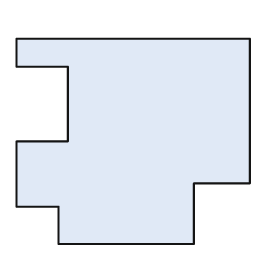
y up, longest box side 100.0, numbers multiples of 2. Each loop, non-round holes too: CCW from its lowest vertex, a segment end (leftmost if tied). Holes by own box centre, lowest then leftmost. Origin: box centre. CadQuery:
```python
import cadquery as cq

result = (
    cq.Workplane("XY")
    .moveTo(-32.0, -44.0)
    .lineTo(26.0, -44.0)
    .lineTo(26.0, -18.0)
    .lineTo(50.0, -18.0)
    .lineTo(50.0, 44.0)
    .lineTo(-50.0, 44.0)
    .lineTo(-50.0, 32.0)
    .lineTo(-28.0, 32.0)
    .lineTo(-28.0, 0.0)
    .lineTo(-50.0, 0.0)
    .lineTo(-50.0, -28.0)
    .lineTo(-32.0, -28.0)
    .close()
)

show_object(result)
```